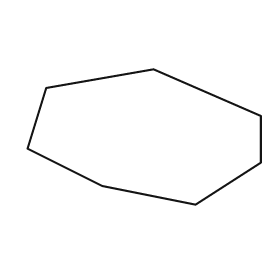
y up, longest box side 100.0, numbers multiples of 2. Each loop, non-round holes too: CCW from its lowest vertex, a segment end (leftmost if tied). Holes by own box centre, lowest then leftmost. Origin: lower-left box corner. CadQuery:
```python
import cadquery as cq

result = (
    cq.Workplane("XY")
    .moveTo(72.0, 0.0)
    .lineTo(100.0, 18.0)
    .lineTo(100.0, 38.0)
    .lineTo(54.0, 58.0)
    .lineTo(8.0, 50.0)
    .lineTo(0.0, 24.0)
    .lineTo(32.0, 8.0)
    .close()
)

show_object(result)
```